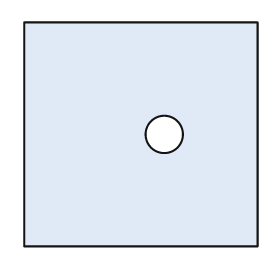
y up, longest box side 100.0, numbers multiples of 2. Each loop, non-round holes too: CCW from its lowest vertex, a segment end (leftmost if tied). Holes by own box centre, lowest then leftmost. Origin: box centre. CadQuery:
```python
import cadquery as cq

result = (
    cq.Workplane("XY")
    .moveTo(-50.0, -48.0)
    .lineTo(50.0, -48.0)
    .lineTo(50.0, 48.0)
    .lineTo(-50.0, 48.0)
    .close()
    .moveTo(10.0, 0.0)
    .circle(8.0)
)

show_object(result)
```